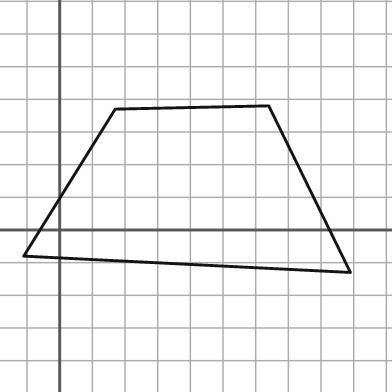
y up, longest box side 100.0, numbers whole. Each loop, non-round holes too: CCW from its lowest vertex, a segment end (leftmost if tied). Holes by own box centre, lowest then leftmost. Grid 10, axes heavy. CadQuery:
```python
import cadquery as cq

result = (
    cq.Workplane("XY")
    .moveTo(89.0, -13.0)
    .lineTo(64.0, 38.0)
    .lineTo(17.0, 37.0)
    .lineTo(-11.0, -8.0)
    .close()
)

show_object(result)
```